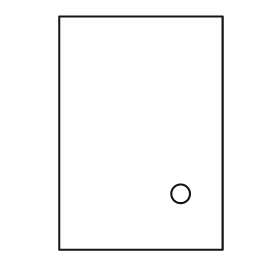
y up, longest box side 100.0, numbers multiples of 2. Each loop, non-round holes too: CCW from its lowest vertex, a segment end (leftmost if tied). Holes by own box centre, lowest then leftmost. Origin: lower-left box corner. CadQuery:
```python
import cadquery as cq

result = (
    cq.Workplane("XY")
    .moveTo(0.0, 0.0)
    .lineTo(70.0, 0.0)
    .lineTo(70.0, 100.0)
    .lineTo(0.0, 100.0)
    .close()
    .moveTo(52.0, 24.0)
    .circle(4.0)
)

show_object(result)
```